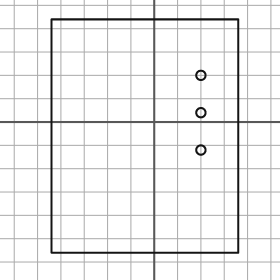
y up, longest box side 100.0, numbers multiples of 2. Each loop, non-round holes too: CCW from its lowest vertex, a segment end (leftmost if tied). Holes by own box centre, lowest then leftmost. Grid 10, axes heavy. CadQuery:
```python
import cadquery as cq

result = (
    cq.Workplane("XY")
    .moveTo(-44.0, -56.0)
    .lineTo(36.0, -56.0)
    .lineTo(36.0, 44.0)
    .lineTo(-44.0, 44.0)
    .close()
    .moveTo(20.0, -12.0)
    .circle(2.0)
    .moveTo(20.0, 4.0)
    .circle(2.0)
    .moveTo(20.0, 20.0)
    .circle(2.0)
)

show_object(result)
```